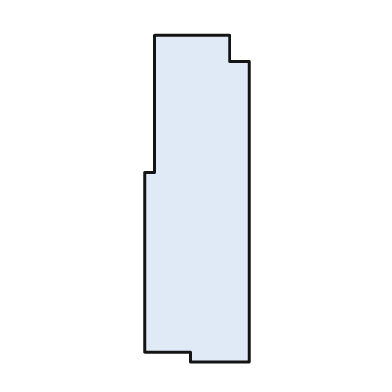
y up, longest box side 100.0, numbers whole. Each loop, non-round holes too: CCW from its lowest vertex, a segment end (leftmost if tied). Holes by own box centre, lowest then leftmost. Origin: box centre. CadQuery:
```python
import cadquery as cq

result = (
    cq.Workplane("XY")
    .moveTo(-2.0, -50.0)
    .lineTo(16.0, -50.0)
    .lineTo(16.0, 42.0)
    .lineTo(10.0, 42.0)
    .lineTo(10.0, 50.0)
    .lineTo(-13.0, 50.0)
    .lineTo(-13.0, 8.0)
    .lineTo(-16.0, 8.0)
    .lineTo(-16.0, -47.0)
    .lineTo(-2.0, -47.0)
    .close()
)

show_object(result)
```